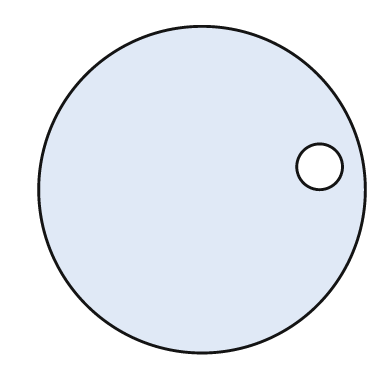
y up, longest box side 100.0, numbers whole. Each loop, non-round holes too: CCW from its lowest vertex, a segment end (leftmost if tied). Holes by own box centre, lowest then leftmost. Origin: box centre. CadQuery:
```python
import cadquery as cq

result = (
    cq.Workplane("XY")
    .moveTo(0.0, 0.0)
    .circle(50.0)
    .moveTo(36.0, 7.0)
    .circle(7.0)
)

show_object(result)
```